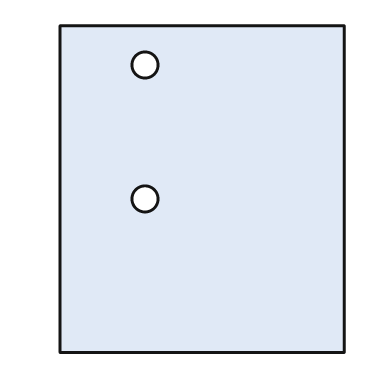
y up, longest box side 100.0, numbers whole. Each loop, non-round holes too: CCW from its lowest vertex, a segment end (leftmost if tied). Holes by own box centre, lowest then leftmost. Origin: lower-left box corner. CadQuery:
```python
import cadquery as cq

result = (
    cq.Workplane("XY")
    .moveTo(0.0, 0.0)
    .lineTo(87.0, 0.0)
    .lineTo(87.0, 100.0)
    .lineTo(0.0, 100.0)
    .close()
    .moveTo(26.0, 47.0)
    .circle(4.0)
    .moveTo(26.0, 88.0)
    .circle(4.0)
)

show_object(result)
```